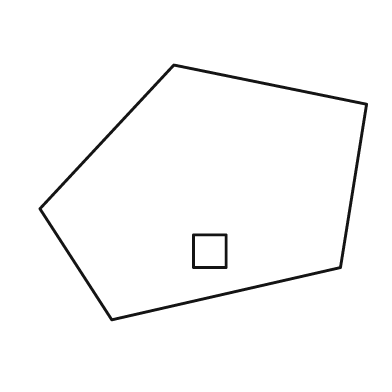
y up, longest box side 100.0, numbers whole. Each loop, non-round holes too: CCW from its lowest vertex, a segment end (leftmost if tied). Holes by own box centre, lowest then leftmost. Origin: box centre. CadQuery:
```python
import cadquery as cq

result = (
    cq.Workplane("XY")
    .moveTo(-28.0, -39.0)
    .lineTo(42.0, -23.0)
    .lineTo(50.0, 27.0)
    .lineTo(-9.0, 39.0)
    .lineTo(-50.0, -5.0)
    .close()
    .moveTo(-3.0, -23.0)
    .lineTo(7.0, -23.0)
    .lineTo(7.0, -13.0)
    .lineTo(-3.0, -13.0)
    .close()
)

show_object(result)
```